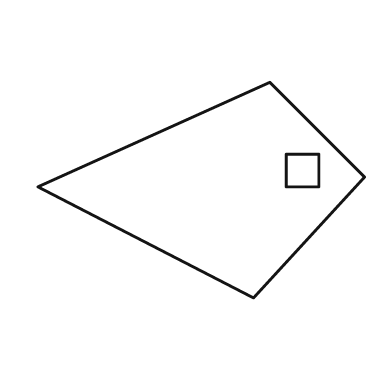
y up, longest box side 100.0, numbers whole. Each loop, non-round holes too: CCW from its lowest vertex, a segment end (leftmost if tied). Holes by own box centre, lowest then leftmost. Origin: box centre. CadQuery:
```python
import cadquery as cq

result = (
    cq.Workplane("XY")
    .moveTo(16.0, -33.0)
    .lineTo(50.0, 4.0)
    .lineTo(21.0, 33.0)
    .lineTo(-50.0, 1.0)
    .close()
    .moveTo(26.0, 1.0)
    .lineTo(36.0, 1.0)
    .lineTo(36.0, 11.0)
    .lineTo(26.0, 11.0)
    .close()
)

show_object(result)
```